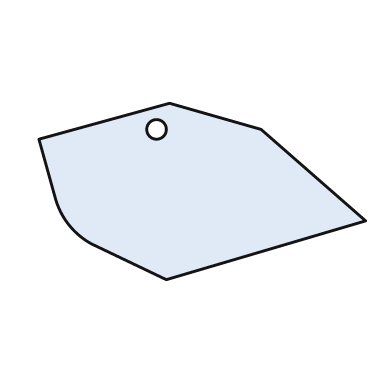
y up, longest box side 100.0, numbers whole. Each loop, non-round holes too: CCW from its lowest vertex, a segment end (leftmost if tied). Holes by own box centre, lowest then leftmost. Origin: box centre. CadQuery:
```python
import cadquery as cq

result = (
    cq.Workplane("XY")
    .moveTo(-11.0, -27.0)
    .lineTo(50.0, -9.0)
    .lineTo(18.0, 19.0)
    .lineTo(-10.0, 27.0)
    .lineTo(-50.0, 16.0)
    .lineTo(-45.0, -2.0)
    .threePointArc((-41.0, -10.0), (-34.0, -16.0))
    .close()
    .moveTo(-14.0, 19.0)
    .circle(3.0)
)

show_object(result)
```